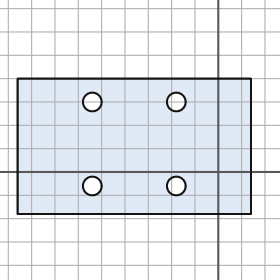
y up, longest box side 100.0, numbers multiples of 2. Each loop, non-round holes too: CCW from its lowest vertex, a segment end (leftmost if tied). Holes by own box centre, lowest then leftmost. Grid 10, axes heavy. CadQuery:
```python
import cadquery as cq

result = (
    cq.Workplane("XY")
    .moveTo(-86.0, -18.0)
    .lineTo(14.0, -18.0)
    .lineTo(14.0, 40.0)
    .lineTo(-86.0, 40.0)
    .close()
    .moveTo(-54.0, -6.0)
    .circle(4.0)
    .moveTo(-18.0, -6.0)
    .circle(4.0)
    .moveTo(-54.0, 30.0)
    .circle(4.0)
    .moveTo(-18.0, 30.0)
    .circle(4.0)
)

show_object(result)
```